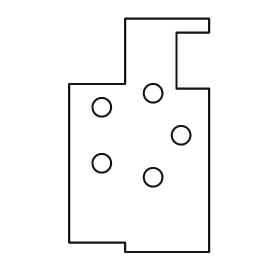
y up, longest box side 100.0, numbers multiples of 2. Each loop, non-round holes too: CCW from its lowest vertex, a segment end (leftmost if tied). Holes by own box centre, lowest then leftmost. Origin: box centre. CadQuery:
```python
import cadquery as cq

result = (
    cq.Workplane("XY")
    .moveTo(-6.0, -50.0)
    .lineTo(30.0, -50.0)
    .lineTo(30.0, 20.0)
    .lineTo(16.0, 20.0)
    .lineTo(16.0, 44.0)
    .lineTo(30.0, 44.0)
    .lineTo(30.0, 50.0)
    .lineTo(-6.0, 50.0)
    .lineTo(-6.0, 22.0)
    .lineTo(-30.0, 22.0)
    .lineTo(-30.0, -46.0)
    .lineTo(-6.0, -46.0)
    .close()
    .moveTo(6.0, -18.0)
    .circle(4.0)
    .moveTo(-16.0, -12.0)
    .circle(4.0)
    .moveTo(18.0, 0.0)
    .circle(4.0)
    .moveTo(-16.0, 12.0)
    .circle(4.0)
    .moveTo(6.0, 18.0)
    .circle(4.0)
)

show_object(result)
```